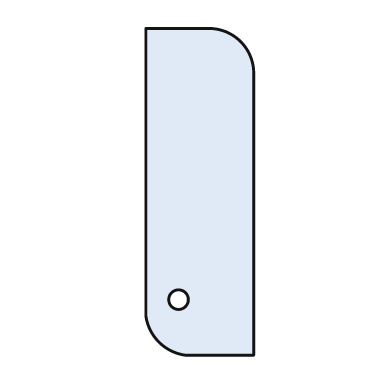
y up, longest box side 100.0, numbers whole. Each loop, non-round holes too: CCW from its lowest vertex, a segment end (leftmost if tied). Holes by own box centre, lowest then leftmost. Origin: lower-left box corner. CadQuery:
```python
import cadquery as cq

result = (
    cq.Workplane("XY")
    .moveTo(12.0, 0.0)
    .lineTo(33.0, 0.0)
    .lineTo(33.0, 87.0)
    .threePointArc((29.0, 96.0), (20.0, 100.0))
    .lineTo(0.0, 100.0)
    .lineTo(0.0, 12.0)
    .threePointArc((4.0, 4.0), (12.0, 0.0))
    .close()
    .moveTo(10.0, 17.0)
    .circle(3.0)
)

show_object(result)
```